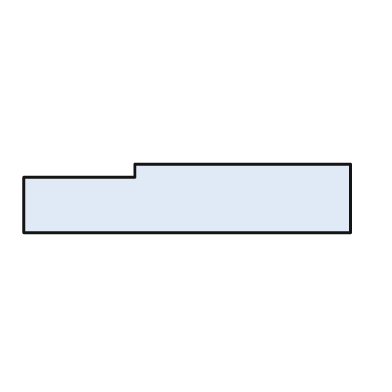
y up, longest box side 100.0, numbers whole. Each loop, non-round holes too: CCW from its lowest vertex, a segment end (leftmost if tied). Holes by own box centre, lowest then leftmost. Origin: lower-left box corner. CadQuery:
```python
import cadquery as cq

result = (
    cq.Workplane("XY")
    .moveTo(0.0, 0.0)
    .lineTo(100.0, 0.0)
    .lineTo(100.0, 21.0)
    .lineTo(34.0, 21.0)
    .lineTo(34.0, 17.0)
    .lineTo(0.0, 17.0)
    .close()
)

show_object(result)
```